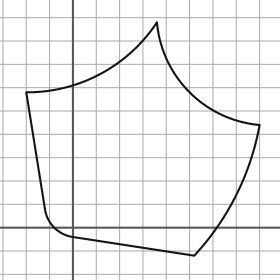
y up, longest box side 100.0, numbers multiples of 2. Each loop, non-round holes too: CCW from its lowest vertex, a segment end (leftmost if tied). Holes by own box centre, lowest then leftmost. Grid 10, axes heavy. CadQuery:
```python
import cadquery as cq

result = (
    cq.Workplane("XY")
    .moveTo(52.0, -12.0)
    .threePointArc((70.0, 14.0), (80.0, 44.0))
    .threePointArc((50.0, 58.0), (36.0, 88.0))
    .threePointArc((12.0, 66.0), (-20.0, 58.0))
    .lineTo(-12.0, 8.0)
    .threePointArc((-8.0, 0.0), (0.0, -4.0))
    .close()
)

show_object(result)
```